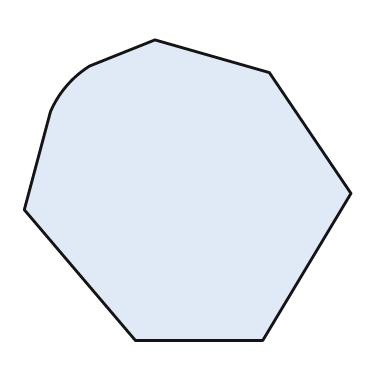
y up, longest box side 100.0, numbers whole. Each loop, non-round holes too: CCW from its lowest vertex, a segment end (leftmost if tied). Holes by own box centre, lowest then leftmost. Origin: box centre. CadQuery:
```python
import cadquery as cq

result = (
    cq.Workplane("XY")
    .moveTo(-16.0, -46.0)
    .lineTo(23.0, -46.0)
    .lineTo(50.0, -1.0)
    .lineTo(25.0, 36.0)
    .lineTo(-10.0, 46.0)
    .lineTo(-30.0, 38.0)
    .threePointArc((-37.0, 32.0), (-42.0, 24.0))
    .lineTo(-50.0, -6.0)
    .close()
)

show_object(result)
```